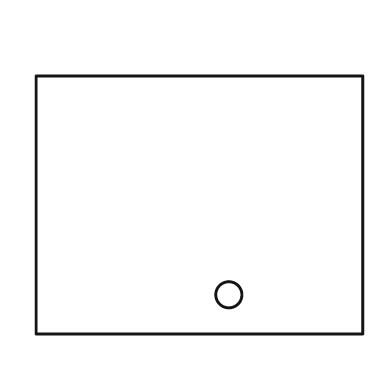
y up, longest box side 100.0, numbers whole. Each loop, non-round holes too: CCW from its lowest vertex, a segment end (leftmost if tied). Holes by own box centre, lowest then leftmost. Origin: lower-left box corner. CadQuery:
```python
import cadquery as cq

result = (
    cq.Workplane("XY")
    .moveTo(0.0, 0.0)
    .lineTo(100.0, 0.0)
    .lineTo(100.0, 79.0)
    .lineTo(0.0, 79.0)
    .close()
    .moveTo(59.0, 12.0)
    .circle(4.0)
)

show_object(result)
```